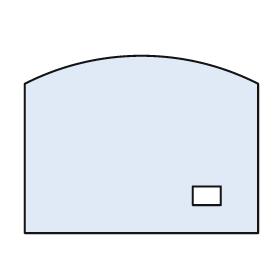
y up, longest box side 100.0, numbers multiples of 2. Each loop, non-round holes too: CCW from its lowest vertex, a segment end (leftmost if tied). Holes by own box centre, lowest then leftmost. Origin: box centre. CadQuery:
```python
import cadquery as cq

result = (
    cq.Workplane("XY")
    .moveTo(-50.0, -38.0)
    .lineTo(50.0, -38.0)
    .lineTo(50.0, 26.0)
    .threePointArc((0.0, 38.0), (-50.0, 26.0))
    .close()
    .moveTo(22.0, -26.0)
    .lineTo(34.0, -26.0)
    .lineTo(34.0, -18.0)
    .lineTo(22.0, -18.0)
    .close()
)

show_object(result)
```